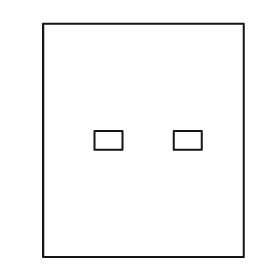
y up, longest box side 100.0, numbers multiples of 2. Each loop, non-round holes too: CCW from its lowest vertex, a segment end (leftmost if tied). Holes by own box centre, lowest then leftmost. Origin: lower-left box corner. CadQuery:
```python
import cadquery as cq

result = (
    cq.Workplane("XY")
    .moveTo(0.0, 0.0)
    .lineTo(86.0, 0.0)
    .lineTo(86.0, 100.0)
    .lineTo(0.0, 100.0)
    .close()
    .moveTo(22.0, 46.0)
    .lineTo(34.0, 46.0)
    .lineTo(34.0, 54.0)
    .lineTo(22.0, 54.0)
    .close()
    .moveTo(56.0, 46.0)
    .lineTo(68.0, 46.0)
    .lineTo(68.0, 54.0)
    .lineTo(56.0, 54.0)
    .close()
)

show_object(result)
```